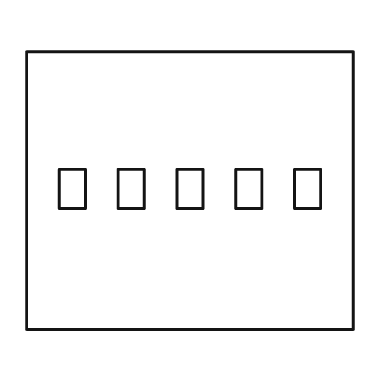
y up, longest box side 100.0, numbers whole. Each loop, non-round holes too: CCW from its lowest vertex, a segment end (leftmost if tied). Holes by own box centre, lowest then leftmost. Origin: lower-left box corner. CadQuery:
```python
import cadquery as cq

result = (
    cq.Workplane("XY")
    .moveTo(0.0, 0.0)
    .lineTo(100.0, 0.0)
    .lineTo(100.0, 85.0)
    .lineTo(0.0, 85.0)
    .close()
    .moveTo(10.0, 37.0)
    .lineTo(18.0, 37.0)
    .lineTo(18.0, 49.0)
    .lineTo(10.0, 49.0)
    .close()
    .moveTo(28.0, 37.0)
    .lineTo(36.0, 37.0)
    .lineTo(36.0, 49.0)
    .lineTo(28.0, 49.0)
    .close()
    .moveTo(46.0, 37.0)
    .lineTo(54.0, 37.0)
    .lineTo(54.0, 49.0)
    .lineTo(46.0, 49.0)
    .close()
    .moveTo(64.0, 37.0)
    .lineTo(72.0, 37.0)
    .lineTo(72.0, 49.0)
    .lineTo(64.0, 49.0)
    .close()
    .moveTo(82.0, 37.0)
    .lineTo(90.0, 37.0)
    .lineTo(90.0, 49.0)
    .lineTo(82.0, 49.0)
    .close()
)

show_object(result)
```